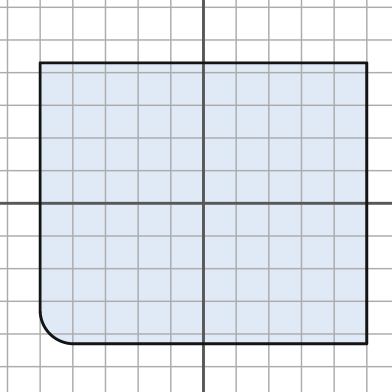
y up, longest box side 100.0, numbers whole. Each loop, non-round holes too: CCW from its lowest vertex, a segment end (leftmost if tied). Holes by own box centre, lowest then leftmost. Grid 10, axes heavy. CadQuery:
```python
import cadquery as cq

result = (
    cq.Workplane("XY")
    .moveTo(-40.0, -43.0)
    .lineTo(50.0, -43.0)
    .lineTo(50.0, 43.0)
    .lineTo(-50.0, 43.0)
    .lineTo(-50.0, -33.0)
    .threePointArc((-47.0, -40.0), (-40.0, -43.0))
    .close()
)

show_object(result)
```